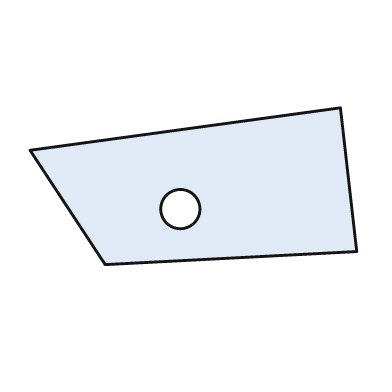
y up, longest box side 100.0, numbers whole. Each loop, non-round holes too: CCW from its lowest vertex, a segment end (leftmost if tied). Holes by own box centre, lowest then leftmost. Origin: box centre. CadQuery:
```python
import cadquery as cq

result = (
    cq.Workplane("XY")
    .moveTo(-27.0, -24.0)
    .lineTo(50.0, -20.0)
    .lineTo(45.0, 24.0)
    .lineTo(-50.0, 11.0)
    .close()
    .moveTo(-4.0, -7.0)
    .circle(6.0)
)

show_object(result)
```